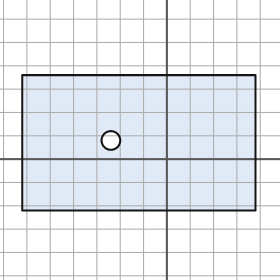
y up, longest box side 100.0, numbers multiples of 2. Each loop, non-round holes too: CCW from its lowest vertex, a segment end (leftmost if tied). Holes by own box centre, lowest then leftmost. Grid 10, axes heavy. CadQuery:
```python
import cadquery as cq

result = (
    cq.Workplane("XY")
    .moveTo(-62.0, -22.0)
    .lineTo(38.0, -22.0)
    .lineTo(38.0, 36.0)
    .lineTo(-62.0, 36.0)
    .close()
    .moveTo(-24.0, 8.0)
    .circle(4.0)
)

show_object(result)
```